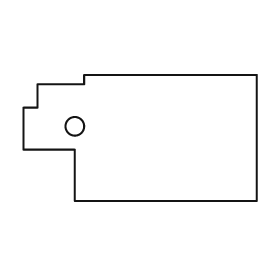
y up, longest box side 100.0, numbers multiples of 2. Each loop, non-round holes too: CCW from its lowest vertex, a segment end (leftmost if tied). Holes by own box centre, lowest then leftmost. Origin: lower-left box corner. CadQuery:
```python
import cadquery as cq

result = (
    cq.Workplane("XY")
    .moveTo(22.0, 0.0)
    .lineTo(100.0, 0.0)
    .lineTo(100.0, 54.0)
    .lineTo(26.0, 54.0)
    .lineTo(26.0, 50.0)
    .lineTo(6.0, 50.0)
    .lineTo(6.0, 40.0)
    .lineTo(0.0, 40.0)
    .lineTo(0.0, 22.0)
    .lineTo(22.0, 22.0)
    .close()
    .moveTo(22.0, 32.0)
    .circle(4.0)
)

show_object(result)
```